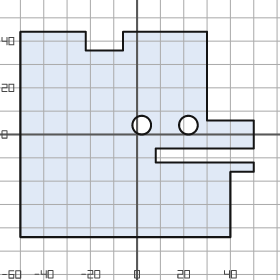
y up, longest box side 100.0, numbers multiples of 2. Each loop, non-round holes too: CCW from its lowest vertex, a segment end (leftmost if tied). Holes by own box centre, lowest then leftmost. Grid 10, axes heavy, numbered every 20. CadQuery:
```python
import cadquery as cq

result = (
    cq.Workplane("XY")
    .moveTo(-50.0, -44.0)
    .lineTo(40.0, -44.0)
    .lineTo(40.0, -16.0)
    .lineTo(50.0, -16.0)
    .lineTo(50.0, -12.0)
    .lineTo(8.0, -12.0)
    .lineTo(8.0, -6.0)
    .lineTo(50.0, -6.0)
    .lineTo(50.0, 6.0)
    .lineTo(30.0, 6.0)
    .lineTo(30.0, 44.0)
    .lineTo(-6.0, 44.0)
    .lineTo(-6.0, 36.0)
    .lineTo(-22.0, 36.0)
    .lineTo(-22.0, 44.0)
    .lineTo(-50.0, 44.0)
    .close()
    .moveTo(2.0, 4.0)
    .circle(4.0)
    .moveTo(22.0, 4.0)
    .circle(4.0)
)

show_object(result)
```